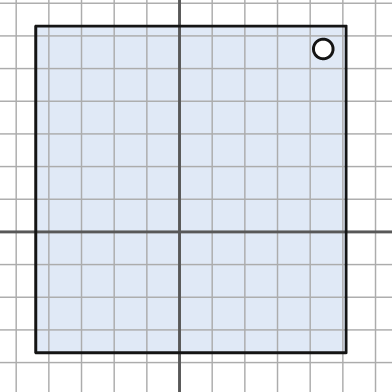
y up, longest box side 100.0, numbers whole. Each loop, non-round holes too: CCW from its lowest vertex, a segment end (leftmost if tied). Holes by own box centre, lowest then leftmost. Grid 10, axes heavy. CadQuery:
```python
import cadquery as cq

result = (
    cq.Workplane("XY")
    .moveTo(-44.0, -37.0)
    .lineTo(51.0, -37.0)
    .lineTo(51.0, 63.0)
    .lineTo(-44.0, 63.0)
    .close()
    .moveTo(44.0, 56.0)
    .circle(3.0)
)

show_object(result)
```